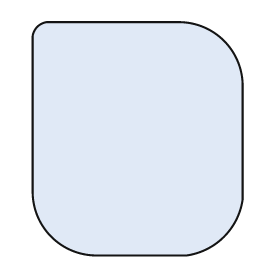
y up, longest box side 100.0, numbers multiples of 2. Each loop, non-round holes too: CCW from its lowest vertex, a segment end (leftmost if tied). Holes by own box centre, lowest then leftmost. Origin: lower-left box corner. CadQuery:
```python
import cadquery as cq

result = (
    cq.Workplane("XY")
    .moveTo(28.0, 0.0)
    .lineTo(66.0, 0.0)
    .threePointArc((82.0, 8.0), (90.0, 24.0))
    .lineTo(90.0, 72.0)
    .threePointArc((82.0, 92.0), (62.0, 100.0))
    .lineTo(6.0, 100.0)
    .threePointArc((2.0, 98.0), (0.0, 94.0))
    .lineTo(0.0, 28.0)
    .threePointArc((8.0, 8.0), (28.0, 0.0))
    .close()
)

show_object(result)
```